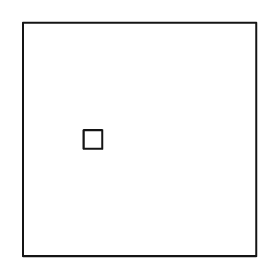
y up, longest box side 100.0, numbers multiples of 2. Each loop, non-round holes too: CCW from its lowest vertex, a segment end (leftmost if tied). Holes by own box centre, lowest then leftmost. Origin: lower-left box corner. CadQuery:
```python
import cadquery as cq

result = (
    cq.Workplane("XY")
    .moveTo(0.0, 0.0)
    .lineTo(100.0, 0.0)
    .lineTo(100.0, 100.0)
    .lineTo(0.0, 100.0)
    .close()
    .moveTo(26.0, 46.0)
    .lineTo(34.0, 46.0)
    .lineTo(34.0, 54.0)
    .lineTo(26.0, 54.0)
    .close()
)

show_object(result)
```